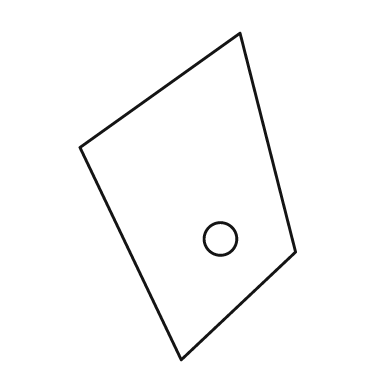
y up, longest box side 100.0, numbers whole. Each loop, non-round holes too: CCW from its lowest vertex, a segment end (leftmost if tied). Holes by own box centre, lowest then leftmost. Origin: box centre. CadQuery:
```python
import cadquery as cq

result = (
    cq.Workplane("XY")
    .moveTo(-2.0, -50.0)
    .lineTo(33.0, -17.0)
    .lineTo(16.0, 50.0)
    .lineTo(-33.0, 15.0)
    .close()
    .moveTo(10.0, -13.0)
    .circle(5.0)
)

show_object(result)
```